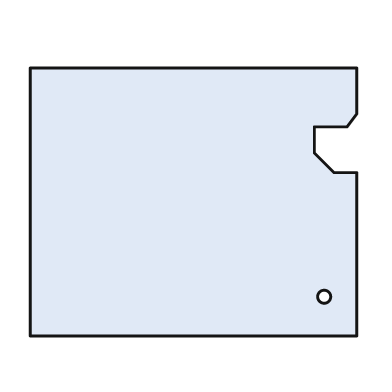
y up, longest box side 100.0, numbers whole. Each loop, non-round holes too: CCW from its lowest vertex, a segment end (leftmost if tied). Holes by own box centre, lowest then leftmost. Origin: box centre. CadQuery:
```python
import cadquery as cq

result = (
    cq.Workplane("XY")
    .moveTo(-50.0, -41.0)
    .lineTo(50.0, -41.0)
    .lineTo(50.0, 9.0)
    .lineTo(43.0, 9.0)
    .lineTo(37.0, 15.0)
    .lineTo(37.0, 23.0)
    .lineTo(47.0, 23.0)
    .lineTo(50.0, 27.0)
    .lineTo(50.0, 41.0)
    .lineTo(-50.0, 41.0)
    .close()
    .moveTo(40.0, -29.0)
    .circle(2.0)
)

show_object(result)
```